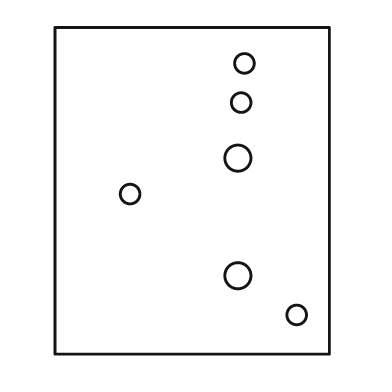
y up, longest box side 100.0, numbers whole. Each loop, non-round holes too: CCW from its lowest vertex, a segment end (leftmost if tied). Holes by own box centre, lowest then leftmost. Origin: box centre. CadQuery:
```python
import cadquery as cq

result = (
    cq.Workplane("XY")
    .moveTo(-42.0, -50.0)
    .lineTo(42.0, -50.0)
    .lineTo(42.0, 50.0)
    .lineTo(-42.0, 50.0)
    .close()
    .moveTo(32.0, -38.0)
    .circle(3.0)
    .moveTo(14.0, -26.0)
    .circle(4.0)
    .moveTo(-19.0, -1.0)
    .circle(3.0)
    .moveTo(14.0, 10.0)
    .circle(4.0)
    .moveTo(15.0, 27.0)
    .circle(3.0)
    .moveTo(16.0, 39.0)
    .circle(3.0)
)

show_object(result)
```